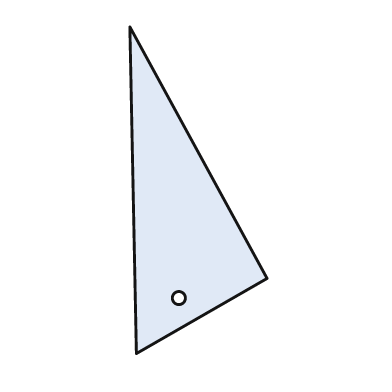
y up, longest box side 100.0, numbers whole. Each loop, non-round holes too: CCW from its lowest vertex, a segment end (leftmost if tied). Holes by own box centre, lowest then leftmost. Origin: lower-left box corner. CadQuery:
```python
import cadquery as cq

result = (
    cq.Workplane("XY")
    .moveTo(2.0, 0.0)
    .lineTo(42.0, 23.0)
    .lineTo(0.0, 100.0)
    .close()
    .moveTo(15.0, 17.0)
    .circle(2.0)
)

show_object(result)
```